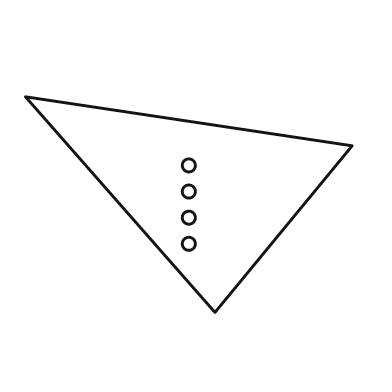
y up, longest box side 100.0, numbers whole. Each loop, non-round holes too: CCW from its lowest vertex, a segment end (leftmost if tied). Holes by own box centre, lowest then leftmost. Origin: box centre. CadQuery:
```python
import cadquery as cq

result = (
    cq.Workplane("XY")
    .moveTo(8.0, -33.0)
    .lineTo(50.0, 18.0)
    .lineTo(-50.0, 33.0)
    .close()
    .moveTo(0.0, -12.0)
    .circle(2.0)
    .moveTo(0.0, -4.0)
    .circle(2.0)
    .moveTo(0.0, 4.0)
    .circle(2.0)
    .moveTo(0.0, 12.0)
    .circle(2.0)
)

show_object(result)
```